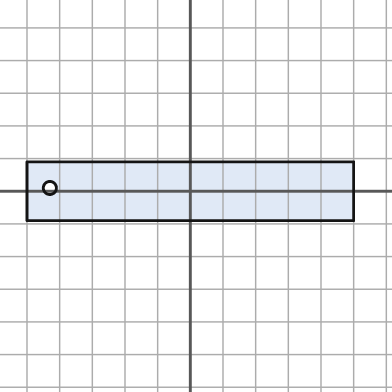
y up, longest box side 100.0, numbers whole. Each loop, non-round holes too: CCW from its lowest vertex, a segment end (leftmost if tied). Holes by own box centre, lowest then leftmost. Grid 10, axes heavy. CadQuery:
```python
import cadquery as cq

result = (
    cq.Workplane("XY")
    .moveTo(-50.0, -9.0)
    .lineTo(50.0, -9.0)
    .lineTo(50.0, 9.0)
    .lineTo(-50.0, 9.0)
    .close()
    .moveTo(-43.0, 1.0)
    .circle(2.0)
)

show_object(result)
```